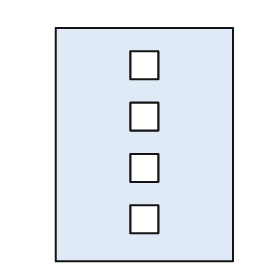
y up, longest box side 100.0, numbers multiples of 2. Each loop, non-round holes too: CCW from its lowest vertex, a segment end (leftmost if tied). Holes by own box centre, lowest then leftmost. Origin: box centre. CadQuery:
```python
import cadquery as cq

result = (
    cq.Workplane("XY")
    .moveTo(-38.0, -50.0)
    .lineTo(38.0, -50.0)
    .lineTo(38.0, 50.0)
    .lineTo(-38.0, 50.0)
    .close()
    .moveTo(-6.0, -38.0)
    .lineTo(6.0, -38.0)
    .lineTo(6.0, -26.0)
    .lineTo(-6.0, -26.0)
    .close()
    .moveTo(-6.0, -16.0)
    .lineTo(6.0, -16.0)
    .lineTo(6.0, -4.0)
    .lineTo(-6.0, -4.0)
    .close()
    .moveTo(-6.0, 6.0)
    .lineTo(6.0, 6.0)
    .lineTo(6.0, 18.0)
    .lineTo(-6.0, 18.0)
    .close()
    .moveTo(-6.0, 28.0)
    .lineTo(6.0, 28.0)
    .lineTo(6.0, 40.0)
    .lineTo(-6.0, 40.0)
    .close()
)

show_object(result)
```